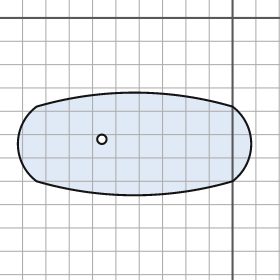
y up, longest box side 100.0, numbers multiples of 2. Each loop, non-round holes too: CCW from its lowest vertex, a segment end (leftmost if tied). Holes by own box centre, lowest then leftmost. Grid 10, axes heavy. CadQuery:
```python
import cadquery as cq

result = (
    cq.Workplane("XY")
    .moveTo(-84.0, -70.0)
    .threePointArc((-42.0, -76.0), (0.0, -70.0))
    .threePointArc((8.0, -54.0), (0.0, -38.0))
    .threePointArc((-42.0, -32.0), (-84.0, -38.0))
    .threePointArc((-92.0, -54.0), (-84.0, -70.0))
    .close()
    .moveTo(-56.0, -52.0)
    .circle(2.0)
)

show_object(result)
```